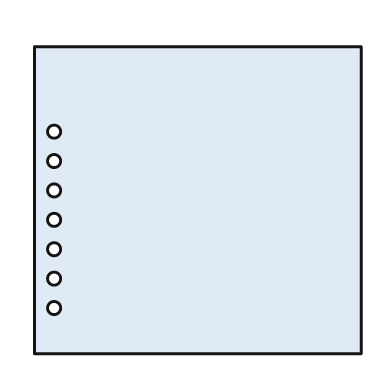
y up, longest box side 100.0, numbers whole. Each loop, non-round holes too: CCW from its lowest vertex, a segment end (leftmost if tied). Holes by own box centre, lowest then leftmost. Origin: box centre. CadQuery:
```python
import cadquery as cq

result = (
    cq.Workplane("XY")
    .moveTo(-50.0, -47.0)
    .lineTo(50.0, -47.0)
    .lineTo(50.0, 47.0)
    .lineTo(-50.0, 47.0)
    .close()
    .moveTo(-44.0, -33.0)
    .circle(2.0)
    .moveTo(-44.0, -24.0)
    .circle(2.0)
    .moveTo(-44.0, -15.0)
    .circle(2.0)
    .moveTo(-44.0, -6.0)
    .circle(2.0)
    .moveTo(-44.0, 3.0)
    .circle(2.0)
    .moveTo(-44.0, 12.0)
    .circle(2.0)
    .moveTo(-44.0, 21.0)
    .circle(2.0)
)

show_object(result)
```